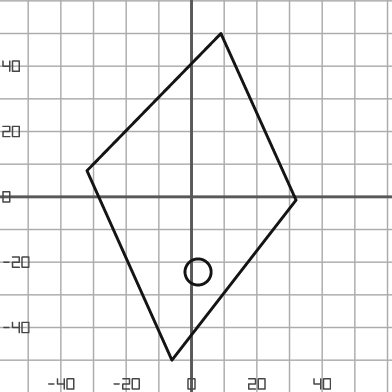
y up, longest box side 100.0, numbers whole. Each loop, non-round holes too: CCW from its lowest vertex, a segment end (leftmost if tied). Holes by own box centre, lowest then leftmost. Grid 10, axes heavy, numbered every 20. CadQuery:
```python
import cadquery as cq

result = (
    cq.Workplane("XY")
    .moveTo(-6.0, -50.0)
    .lineTo(32.0, -1.0)
    .lineTo(9.0, 50.0)
    .lineTo(-32.0, 8.0)
    .close()
    .moveTo(2.0, -23.0)
    .circle(4.0)
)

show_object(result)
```